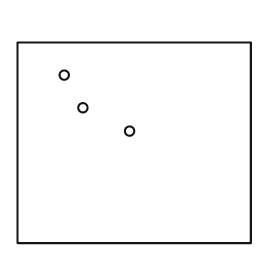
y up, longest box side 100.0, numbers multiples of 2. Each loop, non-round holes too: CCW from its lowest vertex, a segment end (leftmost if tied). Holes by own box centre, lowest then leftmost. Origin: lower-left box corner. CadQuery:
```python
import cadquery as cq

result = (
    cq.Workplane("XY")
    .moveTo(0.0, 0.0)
    .lineTo(100.0, 0.0)
    .lineTo(100.0, 86.0)
    .lineTo(0.0, 86.0)
    .close()
    .moveTo(48.0, 48.0)
    .circle(2.0)
    .moveTo(28.0, 58.0)
    .circle(2.0)
    .moveTo(20.0, 72.0)
    .circle(2.0)
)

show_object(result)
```